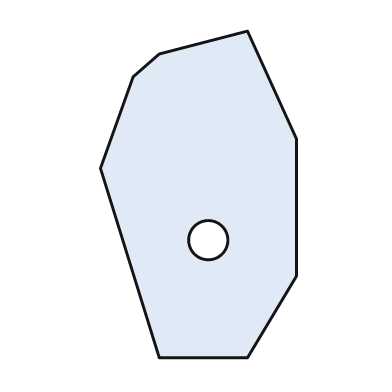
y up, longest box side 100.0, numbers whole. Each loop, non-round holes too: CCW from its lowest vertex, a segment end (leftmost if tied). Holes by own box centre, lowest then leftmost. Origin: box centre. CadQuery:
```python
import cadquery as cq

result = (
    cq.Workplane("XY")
    .moveTo(-12.0, -50.0)
    .lineTo(15.0, -50.0)
    .lineTo(30.0, -25.0)
    .lineTo(30.0, 17.0)
    .lineTo(15.0, 50.0)
    .lineTo(-12.0, 43.0)
    .lineTo(-20.0, 36.0)
    .lineTo(-30.0, 8.0)
    .close()
    .moveTo(3.0, -14.0)
    .circle(6.0)
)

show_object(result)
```